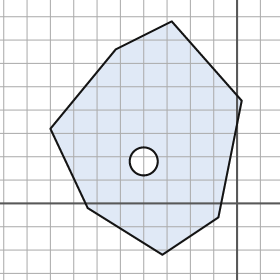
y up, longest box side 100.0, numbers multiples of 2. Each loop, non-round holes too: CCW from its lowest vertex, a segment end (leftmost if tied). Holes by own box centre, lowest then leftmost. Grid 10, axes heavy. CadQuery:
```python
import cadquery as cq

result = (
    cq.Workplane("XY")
    .moveTo(-32.0, -22.0)
    .lineTo(-8.0, -6.0)
    .lineTo(2.0, 44.0)
    .lineTo(-28.0, 78.0)
    .lineTo(-52.0, 66.0)
    .lineTo(-80.0, 32.0)
    .lineTo(-64.0, -2.0)
    .close()
    .moveTo(-40.0, 18.0)
    .circle(6.0)
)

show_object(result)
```